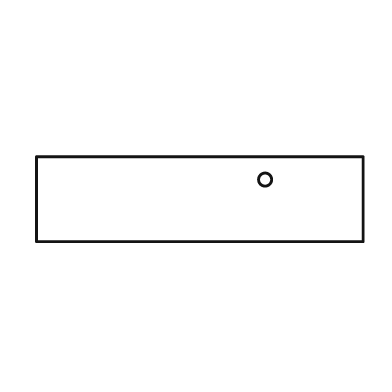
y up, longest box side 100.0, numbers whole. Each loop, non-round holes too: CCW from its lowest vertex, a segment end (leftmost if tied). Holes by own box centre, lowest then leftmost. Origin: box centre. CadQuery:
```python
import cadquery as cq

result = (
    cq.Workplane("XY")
    .moveTo(-50.0, -13.0)
    .lineTo(50.0, -13.0)
    .lineTo(50.0, 13.0)
    .lineTo(-50.0, 13.0)
    .close()
    .moveTo(20.0, 6.0)
    .circle(2.0)
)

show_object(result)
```